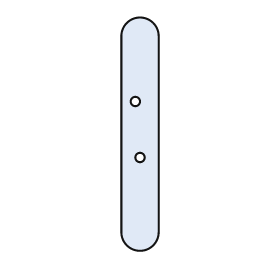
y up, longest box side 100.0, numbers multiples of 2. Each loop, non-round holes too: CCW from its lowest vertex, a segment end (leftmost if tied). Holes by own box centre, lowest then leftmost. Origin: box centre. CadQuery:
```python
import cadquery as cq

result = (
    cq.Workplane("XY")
    .moveTo(-8.0, -42.0)
    .threePointArc((0.0, -50.0), (8.0, -42.0))
    .lineTo(8.0, 42.0)
    .threePointArc((0.0, 50.0), (-8.0, 42.0))
    .close()
    .moveTo(0.0, -10.0)
    .circle(2.0)
    .moveTo(-2.0, 14.0)
    .circle(2.0)
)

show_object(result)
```